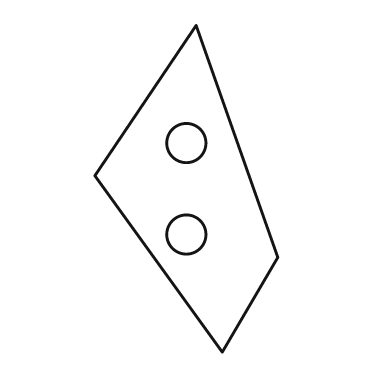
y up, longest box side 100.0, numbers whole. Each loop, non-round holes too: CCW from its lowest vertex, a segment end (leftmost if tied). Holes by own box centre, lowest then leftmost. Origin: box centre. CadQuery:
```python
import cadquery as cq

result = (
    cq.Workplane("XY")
    .moveTo(11.0, -50.0)
    .lineTo(28.0, -21.0)
    .lineTo(3.0, 50.0)
    .lineTo(-28.0, 4.0)
    .close()
    .moveTo(0.0, -14.0)
    .circle(6.0)
    .moveTo(0.0, 14.0)
    .circle(6.0)
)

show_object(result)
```